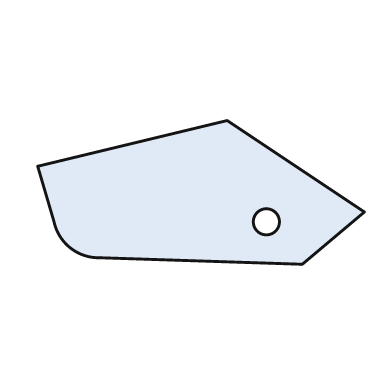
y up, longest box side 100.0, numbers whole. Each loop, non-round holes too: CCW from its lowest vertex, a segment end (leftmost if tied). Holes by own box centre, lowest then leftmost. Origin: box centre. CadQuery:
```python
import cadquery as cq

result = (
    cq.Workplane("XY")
    .moveTo(31.0, -22.0)
    .lineTo(50.0, -6.0)
    .lineTo(8.0, 22.0)
    .lineTo(-50.0, 8.0)
    .lineTo(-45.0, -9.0)
    .threePointArc((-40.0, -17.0), (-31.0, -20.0))
    .close()
    .moveTo(20.0, -9.0)
    .circle(4.0)
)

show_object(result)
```